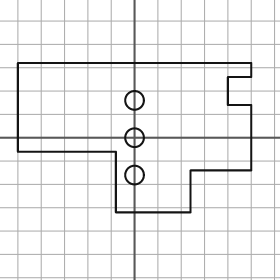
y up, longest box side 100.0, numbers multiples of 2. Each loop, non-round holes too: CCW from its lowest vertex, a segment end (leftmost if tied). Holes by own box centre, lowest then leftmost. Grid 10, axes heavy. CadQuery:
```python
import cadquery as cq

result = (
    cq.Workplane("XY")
    .moveTo(-8.0, -32.0)
    .lineTo(24.0, -32.0)
    .lineTo(24.0, -14.0)
    .lineTo(50.0, -14.0)
    .lineTo(50.0, 14.0)
    .lineTo(40.0, 14.0)
    .lineTo(40.0, 26.0)
    .lineTo(50.0, 26.0)
    .lineTo(50.0, 32.0)
    .lineTo(-50.0, 32.0)
    .lineTo(-50.0, -6.0)
    .lineTo(-8.0, -6.0)
    .close()
    .moveTo(0.0, -16.0)
    .circle(4.0)
    .moveTo(0.0, 0.0)
    .circle(4.0)
    .moveTo(0.0, 16.0)
    .circle(4.0)
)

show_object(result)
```